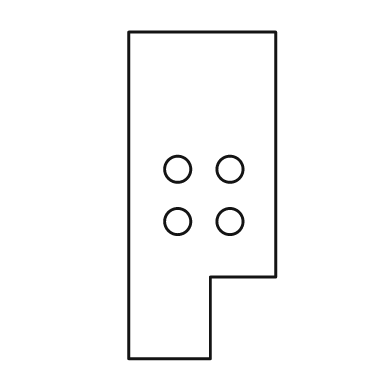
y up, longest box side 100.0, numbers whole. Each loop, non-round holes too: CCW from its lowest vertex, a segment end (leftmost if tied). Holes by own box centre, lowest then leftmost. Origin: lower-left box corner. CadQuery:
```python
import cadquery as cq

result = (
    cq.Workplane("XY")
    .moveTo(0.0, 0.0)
    .lineTo(25.0, 0.0)
    .lineTo(25.0, 25.0)
    .lineTo(45.0, 25.0)
    .lineTo(45.0, 100.0)
    .lineTo(0.0, 100.0)
    .close()
    .moveTo(15.0, 42.0)
    .circle(4.0)
    .moveTo(31.0, 42.0)
    .circle(4.0)
    .moveTo(15.0, 58.0)
    .circle(4.0)
    .moveTo(31.0, 58.0)
    .circle(4.0)
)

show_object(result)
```